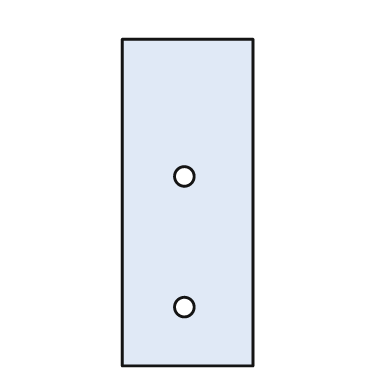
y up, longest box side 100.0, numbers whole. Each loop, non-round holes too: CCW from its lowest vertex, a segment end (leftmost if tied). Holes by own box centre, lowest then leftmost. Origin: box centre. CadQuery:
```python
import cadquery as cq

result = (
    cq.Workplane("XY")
    .moveTo(-20.0, -50.0)
    .lineTo(20.0, -50.0)
    .lineTo(20.0, 50.0)
    .lineTo(-20.0, 50.0)
    .close()
    .moveTo(-1.0, -32.0)
    .circle(3.0)
    .moveTo(-1.0, 8.0)
    .circle(3.0)
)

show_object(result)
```